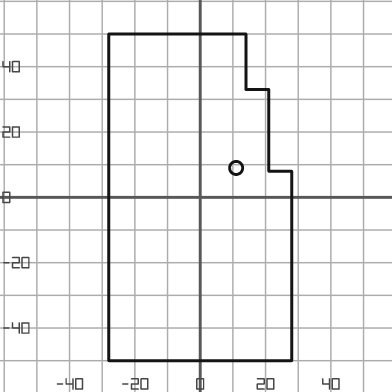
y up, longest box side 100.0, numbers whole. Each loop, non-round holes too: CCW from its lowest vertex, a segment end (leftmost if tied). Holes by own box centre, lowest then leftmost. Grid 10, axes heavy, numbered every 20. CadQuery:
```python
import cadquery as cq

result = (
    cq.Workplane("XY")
    .moveTo(-28.0, -50.0)
    .lineTo(28.0, -50.0)
    .lineTo(28.0, 8.0)
    .lineTo(21.0, 8.0)
    .lineTo(21.0, 33.0)
    .lineTo(14.0, 33.0)
    .lineTo(14.0, 50.0)
    .lineTo(-28.0, 50.0)
    .close()
    .moveTo(11.0, 9.0)
    .circle(2.0)
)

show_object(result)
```